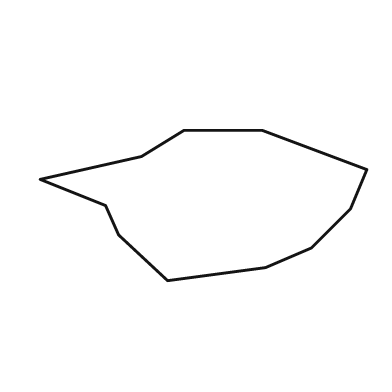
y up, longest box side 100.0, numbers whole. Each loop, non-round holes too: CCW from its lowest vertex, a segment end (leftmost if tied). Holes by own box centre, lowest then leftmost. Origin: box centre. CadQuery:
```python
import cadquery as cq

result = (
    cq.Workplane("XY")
    .moveTo(-11.0, -23.0)
    .lineTo(19.0, -19.0)
    .lineTo(33.0, -13.0)
    .lineTo(45.0, -1.0)
    .lineTo(50.0, 11.0)
    .lineTo(18.0, 23.0)
    .lineTo(-6.0, 23.0)
    .lineTo(-19.0, 15.0)
    .lineTo(-50.0, 8.0)
    .lineTo(-30.0, 0.0)
    .lineTo(-26.0, -9.0)
    .close()
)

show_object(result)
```